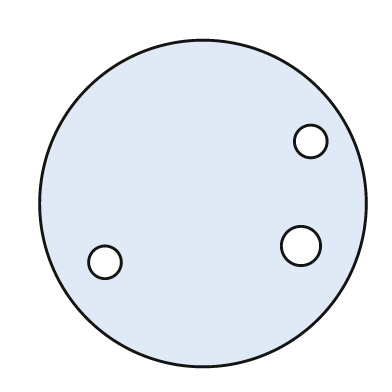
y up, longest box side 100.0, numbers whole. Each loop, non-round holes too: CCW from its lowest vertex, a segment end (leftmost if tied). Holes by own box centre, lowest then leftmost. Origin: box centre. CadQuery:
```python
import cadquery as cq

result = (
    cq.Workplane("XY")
    .moveTo(0.0, 0.0)
    .circle(50.0)
    .moveTo(-30.0, -18.0)
    .circle(5.0)
    .moveTo(30.0, -13.0)
    .circle(6.0)
    .moveTo(33.0, 19.0)
    .circle(5.0)
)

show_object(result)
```